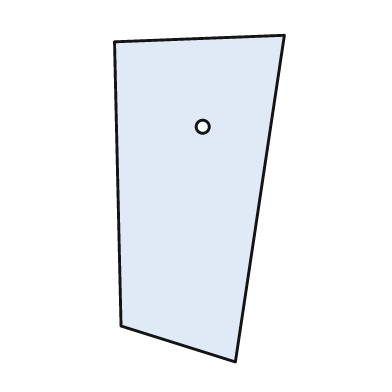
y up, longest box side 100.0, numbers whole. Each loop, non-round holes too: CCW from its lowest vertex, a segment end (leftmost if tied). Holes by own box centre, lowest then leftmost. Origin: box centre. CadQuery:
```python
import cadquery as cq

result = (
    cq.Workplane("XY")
    .moveTo(11.0, -50.0)
    .lineTo(26.0, 50.0)
    .lineTo(-26.0, 48.0)
    .lineTo(-24.0, -39.0)
    .close()
    .moveTo(1.0, 22.0)
    .circle(2.0)
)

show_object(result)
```